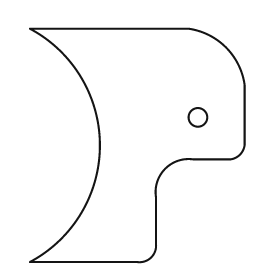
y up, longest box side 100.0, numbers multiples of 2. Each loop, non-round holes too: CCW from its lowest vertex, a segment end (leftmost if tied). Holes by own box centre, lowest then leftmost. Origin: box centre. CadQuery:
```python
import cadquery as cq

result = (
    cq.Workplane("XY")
    .moveTo(-46.0, -50.0)
    .lineTo(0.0, -50.0)
    .threePointArc((6.0, -48.0), (8.0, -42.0))
    .lineTo(8.0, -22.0)
    .threePointArc((12.0, -10.0), (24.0, -6.0))
    .lineTo(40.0, -6.0)
    .threePointArc((44.0, -4.0), (46.0, 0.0))
    .lineTo(46.0, 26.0)
    .threePointArc((38.0, 42.0), (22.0, 50.0))
    .lineTo(-46.0, 50.0)
    .threePointArc((-16.0, 0.0), (-46.0, -50.0))
    .close()
    .moveTo(26.0, 12.0)
    .circle(4.0)
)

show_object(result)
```